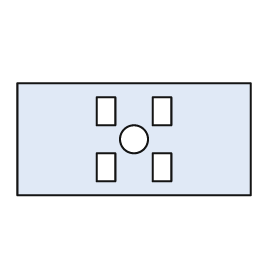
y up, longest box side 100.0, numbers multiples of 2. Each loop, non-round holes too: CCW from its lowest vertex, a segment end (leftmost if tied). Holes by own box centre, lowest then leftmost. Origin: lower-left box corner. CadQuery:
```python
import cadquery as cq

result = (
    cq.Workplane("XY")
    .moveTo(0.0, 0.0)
    .lineTo(100.0, 0.0)
    .lineTo(100.0, 48.0)
    .lineTo(0.0, 48.0)
    .close()
    .moveTo(34.0, 6.0)
    .lineTo(42.0, 6.0)
    .lineTo(42.0, 18.0)
    .lineTo(34.0, 18.0)
    .close()
    .moveTo(58.0, 6.0)
    .lineTo(66.0, 6.0)
    .lineTo(66.0, 18.0)
    .lineTo(58.0, 18.0)
    .close()
    .moveTo(50.0, 24.0)
    .circle(6.0)
    .moveTo(34.0, 30.0)
    .lineTo(42.0, 30.0)
    .lineTo(42.0, 42.0)
    .lineTo(34.0, 42.0)
    .close()
    .moveTo(58.0, 30.0)
    .lineTo(66.0, 30.0)
    .lineTo(66.0, 42.0)
    .lineTo(58.0, 42.0)
    .close()
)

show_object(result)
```